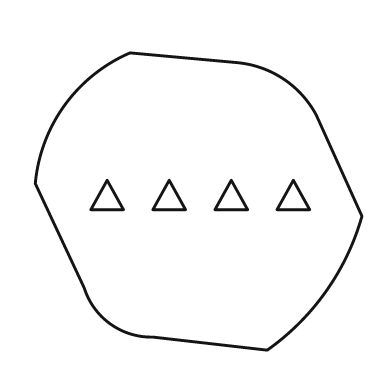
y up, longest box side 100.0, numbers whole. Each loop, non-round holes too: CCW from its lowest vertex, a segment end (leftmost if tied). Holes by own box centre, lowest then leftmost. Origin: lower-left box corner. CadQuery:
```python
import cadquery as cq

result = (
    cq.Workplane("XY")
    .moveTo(71.0, 0.0)
    .threePointArc((89.0, 18.0), (100.0, 41.0))
    .lineTo(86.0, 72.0)
    .threePointArc((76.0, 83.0), (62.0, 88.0))
    .lineTo(29.0, 91.0)
    .threePointArc((9.0, 75.0), (0.0, 51.0))
    .lineTo(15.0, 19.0)
    .threePointArc((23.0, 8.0), (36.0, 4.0))
    .close()
    .moveTo(17.0, 43.0)
    .lineTo(27.0, 43.0)
    .lineTo(22.0, 52.0)
    .close()
    .moveTo(36.0, 43.0)
    .lineTo(46.0, 43.0)
    .lineTo(41.0, 52.0)
    .close()
    .moveTo(55.0, 43.0)
    .lineTo(65.0, 43.0)
    .lineTo(60.0, 52.0)
    .close()
    .moveTo(74.0, 43.0)
    .lineTo(84.0, 43.0)
    .lineTo(79.0, 52.0)
    .close()
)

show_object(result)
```